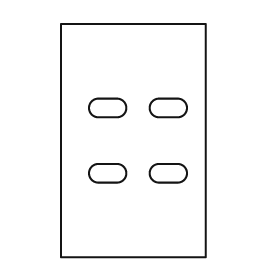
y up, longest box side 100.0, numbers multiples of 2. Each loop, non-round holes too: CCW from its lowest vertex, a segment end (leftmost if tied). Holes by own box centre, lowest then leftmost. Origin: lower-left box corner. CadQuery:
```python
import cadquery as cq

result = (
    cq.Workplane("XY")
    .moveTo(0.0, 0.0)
    .lineTo(62.0, 0.0)
    .lineTo(62.0, 100.0)
    .lineTo(0.0, 100.0)
    .close()
    .moveTo(16.0, 32.0)
    .lineTo(24.0, 32.0)
    .threePointArc((28.0, 36.0), (24.0, 40.0))
    .lineTo(16.0, 40.0)
    .threePointArc((12.0, 36.0), (16.0, 32.0))
    .close()
    .moveTo(42.0, 32.0)
    .lineTo(50.0, 32.0)
    .threePointArc((54.0, 36.0), (50.0, 40.0))
    .lineTo(42.0, 40.0)
    .threePointArc((38.0, 36.0), (42.0, 32.0))
    .close()
    .moveTo(16.0, 60.0)
    .lineTo(24.0, 60.0)
    .threePointArc((28.0, 64.0), (24.0, 68.0))
    .lineTo(16.0, 68.0)
    .threePointArc((12.0, 64.0), (16.0, 60.0))
    .close()
    .moveTo(42.0, 60.0)
    .lineTo(50.0, 60.0)
    .threePointArc((54.0, 64.0), (50.0, 68.0))
    .lineTo(42.0, 68.0)
    .threePointArc((38.0, 64.0), (42.0, 60.0))
    .close()
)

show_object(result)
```